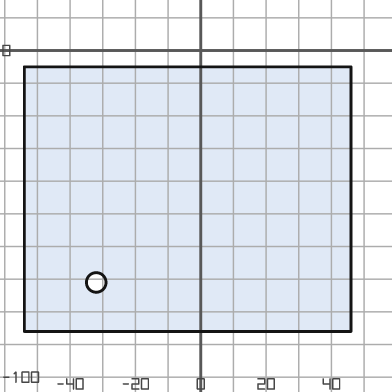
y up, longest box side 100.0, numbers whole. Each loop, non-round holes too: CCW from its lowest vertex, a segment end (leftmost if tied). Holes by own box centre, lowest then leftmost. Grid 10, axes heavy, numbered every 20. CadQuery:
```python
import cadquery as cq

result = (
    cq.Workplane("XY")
    .moveTo(-54.0, -86.0)
    .lineTo(46.0, -86.0)
    .lineTo(46.0, -5.0)
    .lineTo(-54.0, -5.0)
    .close()
    .moveTo(-32.0, -71.0)
    .circle(3.0)
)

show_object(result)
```